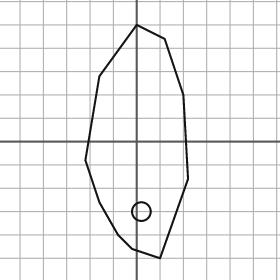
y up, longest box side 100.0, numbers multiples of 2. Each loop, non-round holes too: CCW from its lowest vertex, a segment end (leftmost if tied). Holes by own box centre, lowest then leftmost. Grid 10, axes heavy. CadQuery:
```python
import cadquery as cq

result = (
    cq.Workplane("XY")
    .moveTo(10.0, -50.0)
    .lineTo(22.0, -16.0)
    .lineTo(20.0, 20.0)
    .lineTo(12.0, 44.0)
    .lineTo(0.0, 50.0)
    .lineTo(-16.0, 28.0)
    .lineTo(-22.0, -8.0)
    .lineTo(-16.0, -26.0)
    .lineTo(-8.0, -40.0)
    .lineTo(-2.0, -46.0)
    .close()
    .moveTo(2.0, -30.0)
    .circle(4.0)
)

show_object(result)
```